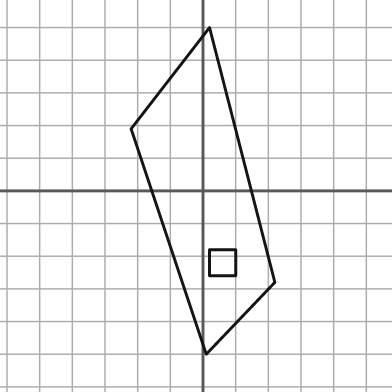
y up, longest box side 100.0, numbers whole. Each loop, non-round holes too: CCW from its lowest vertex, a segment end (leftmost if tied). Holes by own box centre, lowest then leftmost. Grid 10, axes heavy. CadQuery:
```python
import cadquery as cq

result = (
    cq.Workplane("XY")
    .moveTo(1.0, -50.0)
    .lineTo(22.0, -28.0)
    .lineTo(2.0, 50.0)
    .lineTo(-22.0, 19.0)
    .close()
    .moveTo(2.0, -26.0)
    .lineTo(10.0, -26.0)
    .lineTo(10.0, -18.0)
    .lineTo(2.0, -18.0)
    .close()
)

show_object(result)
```